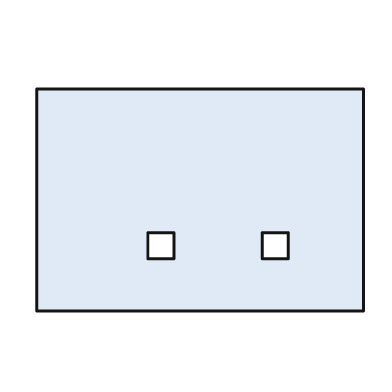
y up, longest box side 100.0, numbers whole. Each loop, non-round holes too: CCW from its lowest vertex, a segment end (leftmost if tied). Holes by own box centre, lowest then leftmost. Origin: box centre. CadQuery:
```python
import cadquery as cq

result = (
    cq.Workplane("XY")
    .moveTo(-50.0, -34.0)
    .lineTo(50.0, -34.0)
    .lineTo(50.0, 34.0)
    .lineTo(-50.0, 34.0)
    .close()
    .moveTo(-16.0, -18.0)
    .lineTo(-8.0, -18.0)
    .lineTo(-8.0, -10.0)
    .lineTo(-16.0, -10.0)
    .close()
    .moveTo(19.0, -18.0)
    .lineTo(27.0, -18.0)
    .lineTo(27.0, -10.0)
    .lineTo(19.0, -10.0)
    .close()
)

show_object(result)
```